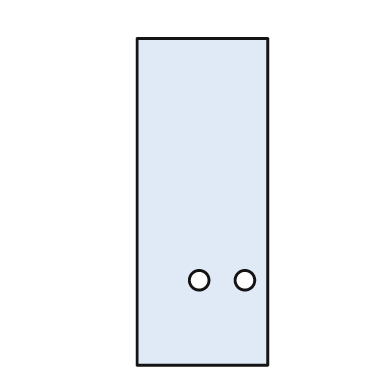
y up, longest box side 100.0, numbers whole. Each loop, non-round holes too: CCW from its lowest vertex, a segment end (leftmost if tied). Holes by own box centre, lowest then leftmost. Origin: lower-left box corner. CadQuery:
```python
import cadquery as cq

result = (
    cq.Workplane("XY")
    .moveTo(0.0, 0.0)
    .lineTo(40.0, 0.0)
    .lineTo(40.0, 100.0)
    .lineTo(0.0, 100.0)
    .close()
    .moveTo(19.0, 26.0)
    .circle(3.0)
    .moveTo(33.0, 26.0)
    .circle(3.0)
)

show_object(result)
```